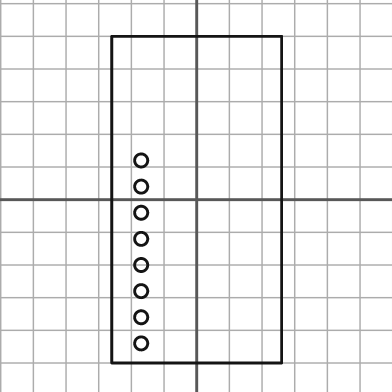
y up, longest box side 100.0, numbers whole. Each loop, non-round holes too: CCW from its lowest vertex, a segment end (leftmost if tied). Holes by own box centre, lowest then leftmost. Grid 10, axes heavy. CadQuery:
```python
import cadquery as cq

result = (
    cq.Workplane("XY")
    .moveTo(-26.0, -50.0)
    .lineTo(26.0, -50.0)
    .lineTo(26.0, 50.0)
    .lineTo(-26.0, 50.0)
    .close()
    .moveTo(-17.0, -44.0)
    .circle(2.0)
    .moveTo(-17.0, -36.0)
    .circle(2.0)
    .moveTo(-17.0, -28.0)
    .circle(2.0)
    .moveTo(-17.0, -20.0)
    .circle(2.0)
    .moveTo(-17.0, -12.0)
    .circle(2.0)
    .moveTo(-17.0, -4.0)
    .circle(2.0)
    .moveTo(-17.0, 4.0)
    .circle(2.0)
    .moveTo(-17.0, 12.0)
    .circle(2.0)
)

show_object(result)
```